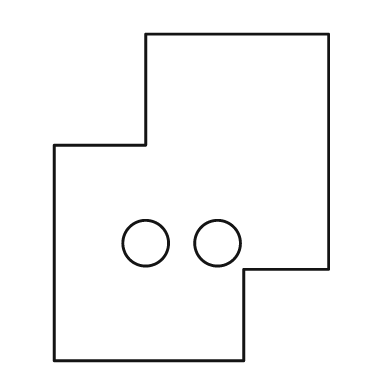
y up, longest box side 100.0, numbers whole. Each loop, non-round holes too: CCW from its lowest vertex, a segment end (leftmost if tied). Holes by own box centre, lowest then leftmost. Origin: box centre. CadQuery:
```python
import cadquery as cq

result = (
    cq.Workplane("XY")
    .moveTo(-42.0, -50.0)
    .lineTo(16.0, -50.0)
    .lineTo(16.0, -22.0)
    .lineTo(42.0, -22.0)
    .lineTo(42.0, 50.0)
    .lineTo(-14.0, 50.0)
    .lineTo(-14.0, 16.0)
    .lineTo(-42.0, 16.0)
    .close()
    .moveTo(-14.0, -14.0)
    .circle(7.0)
    .moveTo(8.0, -14.0)
    .circle(7.0)
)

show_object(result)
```